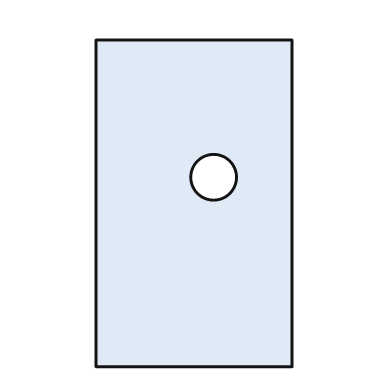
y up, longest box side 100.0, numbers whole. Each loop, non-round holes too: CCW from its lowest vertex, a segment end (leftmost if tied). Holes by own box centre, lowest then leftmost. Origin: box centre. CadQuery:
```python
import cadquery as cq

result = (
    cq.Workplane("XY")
    .moveTo(-30.0, -50.0)
    .lineTo(30.0, -50.0)
    .lineTo(30.0, 50.0)
    .lineTo(-30.0, 50.0)
    .close()
    .moveTo(6.0, 8.0)
    .circle(7.0)
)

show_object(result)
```